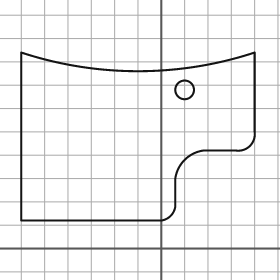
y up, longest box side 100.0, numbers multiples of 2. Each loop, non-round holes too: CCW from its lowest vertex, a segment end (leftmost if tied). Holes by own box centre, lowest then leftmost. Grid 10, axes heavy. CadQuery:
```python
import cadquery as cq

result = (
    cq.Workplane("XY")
    .moveTo(-60.0, 12.0)
    .lineTo(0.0, 12.0)
    .threePointArc((4.0, 14.0), (6.0, 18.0))
    .lineTo(6.0, 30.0)
    .threePointArc((10.0, 38.0), (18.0, 42.0))
    .lineTo(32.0, 42.0)
    .threePointArc((38.0, 44.0), (40.0, 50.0))
    .lineTo(40.0, 84.0)
    .threePointArc((-10.0, 76.0), (-60.0, 84.0))
    .close()
    .moveTo(10.0, 68.0)
    .circle(4.0)
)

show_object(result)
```